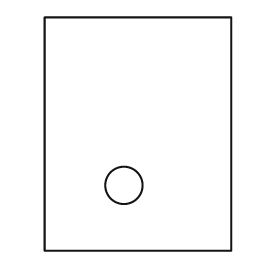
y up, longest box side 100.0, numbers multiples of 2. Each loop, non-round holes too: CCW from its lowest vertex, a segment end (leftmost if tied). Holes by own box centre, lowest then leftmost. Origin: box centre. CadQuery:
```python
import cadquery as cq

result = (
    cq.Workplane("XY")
    .moveTo(-40.0, -50.0)
    .lineTo(40.0, -50.0)
    .lineTo(40.0, 50.0)
    .lineTo(-40.0, 50.0)
    .close()
    .moveTo(-6.0, -22.0)
    .circle(8.0)
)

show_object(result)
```